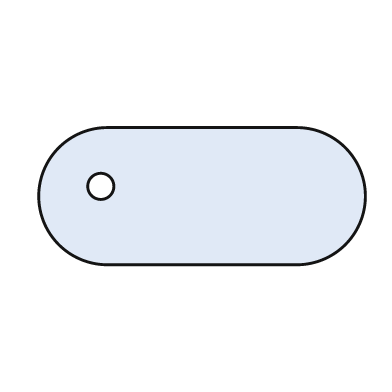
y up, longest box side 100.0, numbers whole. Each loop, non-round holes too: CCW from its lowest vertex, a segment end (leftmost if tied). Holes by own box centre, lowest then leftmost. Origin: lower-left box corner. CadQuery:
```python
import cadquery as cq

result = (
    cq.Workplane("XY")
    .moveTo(21.0, 0.0)
    .lineTo(79.0, 0.0)
    .threePointArc((100.0, 21.0), (79.0, 42.0))
    .lineTo(21.0, 42.0)
    .threePointArc((0.0, 21.0), (21.0, 0.0))
    .close()
    .moveTo(19.0, 24.0)
    .circle(4.0)
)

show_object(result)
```